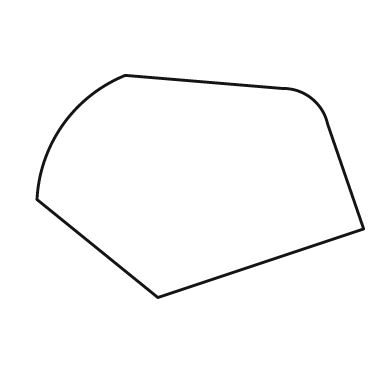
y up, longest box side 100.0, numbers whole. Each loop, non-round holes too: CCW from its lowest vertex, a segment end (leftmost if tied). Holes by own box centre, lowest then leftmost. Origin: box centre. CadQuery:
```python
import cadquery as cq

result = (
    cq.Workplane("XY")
    .moveTo(-13.0, -34.0)
    .lineTo(50.0, -13.0)
    .lineTo(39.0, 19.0)
    .threePointArc((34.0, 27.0), (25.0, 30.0))
    .lineTo(-23.0, 34.0)
    .threePointArc((-42.0, 19.0), (-50.0, -4.0))
    .close()
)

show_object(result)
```